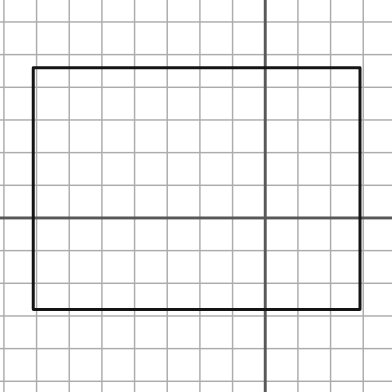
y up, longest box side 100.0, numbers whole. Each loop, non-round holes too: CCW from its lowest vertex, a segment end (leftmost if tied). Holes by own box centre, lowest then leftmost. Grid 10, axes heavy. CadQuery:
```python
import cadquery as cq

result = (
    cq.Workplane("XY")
    .moveTo(-71.0, -28.0)
    .lineTo(29.0, -28.0)
    .lineTo(29.0, 46.0)
    .lineTo(-71.0, 46.0)
    .close()
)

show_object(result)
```